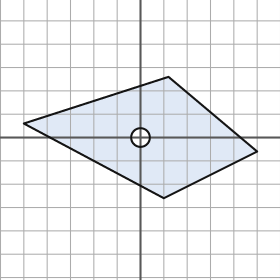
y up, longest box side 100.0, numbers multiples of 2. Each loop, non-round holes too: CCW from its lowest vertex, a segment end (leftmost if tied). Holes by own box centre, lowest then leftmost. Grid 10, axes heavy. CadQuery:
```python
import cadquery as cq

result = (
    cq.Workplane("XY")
    .moveTo(10.0, -26.0)
    .lineTo(50.0, -6.0)
    .lineTo(12.0, 26.0)
    .lineTo(-50.0, 6.0)
    .close()
    .moveTo(0.0, 0.0)
    .circle(4.0)
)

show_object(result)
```